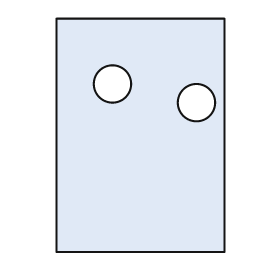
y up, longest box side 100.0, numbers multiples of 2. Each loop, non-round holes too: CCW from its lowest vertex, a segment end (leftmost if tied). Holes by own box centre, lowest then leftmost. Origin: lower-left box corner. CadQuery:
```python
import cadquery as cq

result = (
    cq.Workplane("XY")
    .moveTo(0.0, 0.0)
    .lineTo(72.0, 0.0)
    .lineTo(72.0, 100.0)
    .lineTo(0.0, 100.0)
    .close()
    .moveTo(60.0, 64.0)
    .circle(8.0)
    .moveTo(24.0, 72.0)
    .circle(8.0)
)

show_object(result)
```